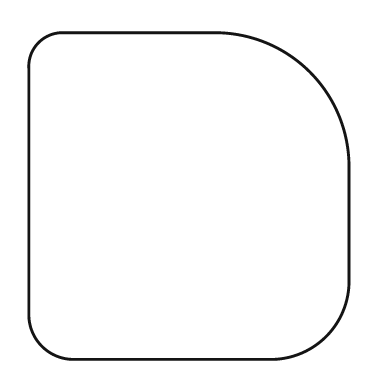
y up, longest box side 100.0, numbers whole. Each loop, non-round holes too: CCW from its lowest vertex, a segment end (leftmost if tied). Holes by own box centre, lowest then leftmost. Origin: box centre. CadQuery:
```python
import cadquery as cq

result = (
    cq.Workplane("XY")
    .moveTo(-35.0, -50.0)
    .lineTo(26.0, -50.0)
    .threePointArc((42.0, -43.0), (49.0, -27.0))
    .lineTo(49.0, 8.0)
    .threePointArc((37.0, 38.0), (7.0, 50.0))
    .lineTo(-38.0, 50.0)
    .threePointArc((-46.0, 47.0), (-49.0, 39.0))
    .lineTo(-49.0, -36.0)
    .threePointArc((-45.0, -46.0), (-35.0, -50.0))
    .close()
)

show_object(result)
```